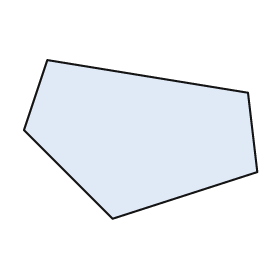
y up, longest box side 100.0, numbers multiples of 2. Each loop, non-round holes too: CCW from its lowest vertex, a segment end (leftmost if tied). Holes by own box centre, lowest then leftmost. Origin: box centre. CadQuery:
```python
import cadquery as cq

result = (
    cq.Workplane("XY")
    .moveTo(-12.0, -34.0)
    .lineTo(50.0, -14.0)
    .lineTo(46.0, 20.0)
    .lineTo(-40.0, 34.0)
    .lineTo(-50.0, 4.0)
    .close()
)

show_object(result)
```